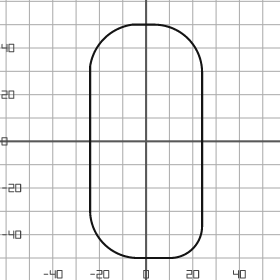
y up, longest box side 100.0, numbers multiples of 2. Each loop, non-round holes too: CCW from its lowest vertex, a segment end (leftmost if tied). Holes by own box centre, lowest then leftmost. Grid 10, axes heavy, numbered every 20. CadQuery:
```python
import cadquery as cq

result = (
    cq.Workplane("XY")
    .moveTo(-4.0, -50.0)
    .lineTo(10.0, -50.0)
    .threePointArc((20.0, -46.0), (24.0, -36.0))
    .lineTo(24.0, 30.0)
    .threePointArc((18.0, 44.0), (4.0, 50.0))
    .lineTo(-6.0, 50.0)
    .threePointArc((-18.0, 44.0), (-24.0, 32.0))
    .lineTo(-24.0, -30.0)
    .threePointArc((-18.0, -44.0), (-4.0, -50.0))
    .close()
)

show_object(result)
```